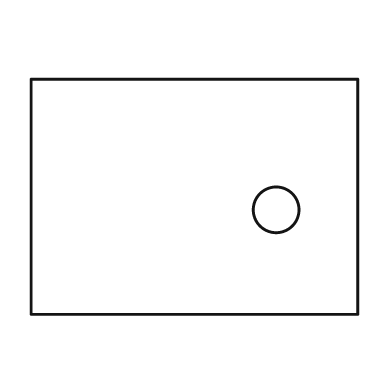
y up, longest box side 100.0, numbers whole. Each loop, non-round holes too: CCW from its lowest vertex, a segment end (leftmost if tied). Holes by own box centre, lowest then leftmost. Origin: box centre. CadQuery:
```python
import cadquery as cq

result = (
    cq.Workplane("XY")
    .moveTo(-50.0, -36.0)
    .lineTo(50.0, -36.0)
    .lineTo(50.0, 36.0)
    .lineTo(-50.0, 36.0)
    .close()
    .moveTo(25.0, -4.0)
    .circle(7.0)
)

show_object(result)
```